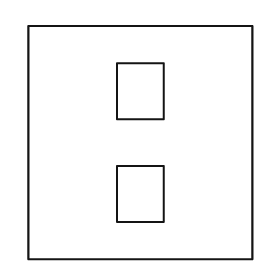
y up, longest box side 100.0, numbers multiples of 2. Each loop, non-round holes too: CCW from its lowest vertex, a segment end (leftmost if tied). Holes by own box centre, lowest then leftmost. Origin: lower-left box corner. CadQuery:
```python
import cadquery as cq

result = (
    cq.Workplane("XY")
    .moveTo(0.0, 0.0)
    .lineTo(96.0, 0.0)
    .lineTo(96.0, 100.0)
    .lineTo(0.0, 100.0)
    .close()
    .moveTo(38.0, 16.0)
    .lineTo(58.0, 16.0)
    .lineTo(58.0, 40.0)
    .lineTo(38.0, 40.0)
    .close()
    .moveTo(38.0, 60.0)
    .lineTo(58.0, 60.0)
    .lineTo(58.0, 84.0)
    .lineTo(38.0, 84.0)
    .close()
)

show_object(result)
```